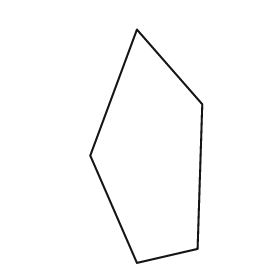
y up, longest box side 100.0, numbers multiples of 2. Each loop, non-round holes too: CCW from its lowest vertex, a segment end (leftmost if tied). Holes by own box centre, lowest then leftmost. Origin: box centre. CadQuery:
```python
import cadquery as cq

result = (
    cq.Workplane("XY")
    .moveTo(-4.0, -50.0)
    .lineTo(22.0, -44.0)
    .lineTo(24.0, 18.0)
    .lineTo(-4.0, 50.0)
    .lineTo(-24.0, -4.0)
    .close()
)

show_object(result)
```